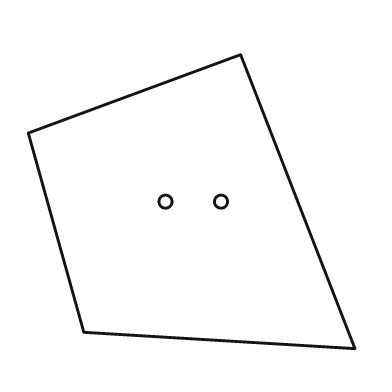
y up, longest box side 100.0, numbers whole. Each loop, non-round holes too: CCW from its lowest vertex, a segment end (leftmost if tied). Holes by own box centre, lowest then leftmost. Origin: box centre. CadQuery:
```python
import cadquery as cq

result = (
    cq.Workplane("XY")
    .moveTo(50.0, -45.0)
    .lineTo(15.0, 45.0)
    .lineTo(-50.0, 21.0)
    .lineTo(-33.0, -40.0)
    .close()
    .moveTo(-8.0, 0.0)
    .circle(2.0)
    .moveTo(9.0, 0.0)
    .circle(2.0)
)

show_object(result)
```